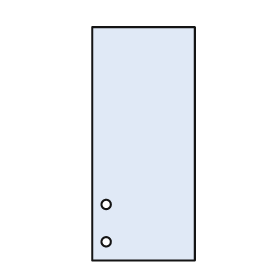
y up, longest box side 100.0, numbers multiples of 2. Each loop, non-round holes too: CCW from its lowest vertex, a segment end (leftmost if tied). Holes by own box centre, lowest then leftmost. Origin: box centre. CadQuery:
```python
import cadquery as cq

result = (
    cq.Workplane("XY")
    .moveTo(-22.0, -50.0)
    .lineTo(22.0, -50.0)
    .lineTo(22.0, 50.0)
    .lineTo(-22.0, 50.0)
    .close()
    .moveTo(-16.0, -42.0)
    .circle(2.0)
    .moveTo(-16.0, -26.0)
    .circle(2.0)
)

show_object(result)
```